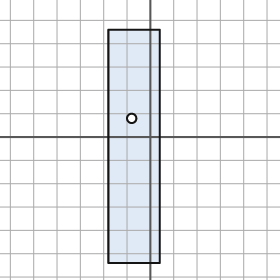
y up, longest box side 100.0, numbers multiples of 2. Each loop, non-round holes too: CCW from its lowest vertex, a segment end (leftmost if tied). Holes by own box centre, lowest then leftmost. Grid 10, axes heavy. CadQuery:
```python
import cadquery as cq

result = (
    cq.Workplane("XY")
    .moveTo(-18.0, -54.0)
    .lineTo(4.0, -54.0)
    .lineTo(4.0, 46.0)
    .lineTo(-18.0, 46.0)
    .close()
    .moveTo(-8.0, 8.0)
    .circle(2.0)
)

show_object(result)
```